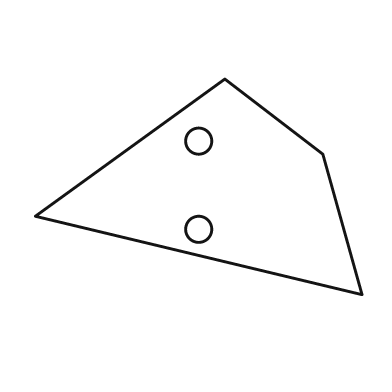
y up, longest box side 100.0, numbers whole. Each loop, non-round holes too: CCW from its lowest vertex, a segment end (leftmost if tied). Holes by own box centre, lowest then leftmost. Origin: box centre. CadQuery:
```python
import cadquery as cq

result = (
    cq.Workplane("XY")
    .moveTo(50.0, -33.0)
    .lineTo(38.0, 10.0)
    .lineTo(8.0, 33.0)
    .lineTo(-50.0, -9.0)
    .close()
    .moveTo(0.0, -13.0)
    .circle(4.0)
    .moveTo(0.0, 14.0)
    .circle(4.0)
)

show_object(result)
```